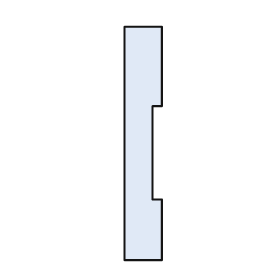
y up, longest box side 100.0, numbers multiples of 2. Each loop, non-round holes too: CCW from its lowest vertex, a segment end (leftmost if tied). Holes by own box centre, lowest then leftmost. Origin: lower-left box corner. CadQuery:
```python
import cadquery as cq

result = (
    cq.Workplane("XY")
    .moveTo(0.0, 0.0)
    .lineTo(16.0, 0.0)
    .lineTo(16.0, 26.0)
    .lineTo(12.0, 26.0)
    .lineTo(12.0, 66.0)
    .lineTo(16.0, 66.0)
    .lineTo(16.0, 100.0)
    .lineTo(0.0, 100.0)
    .close()
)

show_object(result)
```